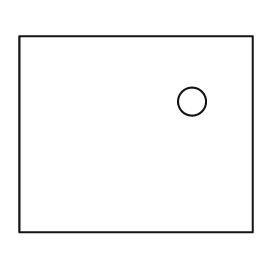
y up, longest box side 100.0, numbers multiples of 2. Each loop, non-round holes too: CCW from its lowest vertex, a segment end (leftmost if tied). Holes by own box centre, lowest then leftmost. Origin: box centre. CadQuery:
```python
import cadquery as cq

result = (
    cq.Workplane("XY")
    .moveTo(-50.0, -42.0)
    .lineTo(50.0, -42.0)
    .lineTo(50.0, 42.0)
    .lineTo(-50.0, 42.0)
    .close()
    .moveTo(24.0, 14.0)
    .circle(6.0)
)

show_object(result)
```